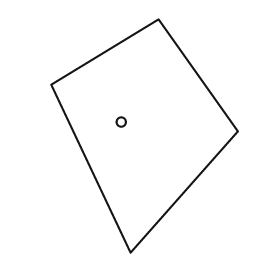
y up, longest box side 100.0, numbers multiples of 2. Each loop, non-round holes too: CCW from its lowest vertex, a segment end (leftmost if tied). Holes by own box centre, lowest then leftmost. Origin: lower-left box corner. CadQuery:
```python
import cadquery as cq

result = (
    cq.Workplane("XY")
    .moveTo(34.0, 0.0)
    .lineTo(80.0, 52.0)
    .lineTo(46.0, 100.0)
    .lineTo(0.0, 72.0)
    .close()
    .moveTo(30.0, 56.0)
    .circle(2.0)
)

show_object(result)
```